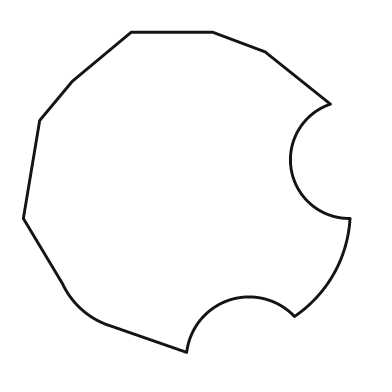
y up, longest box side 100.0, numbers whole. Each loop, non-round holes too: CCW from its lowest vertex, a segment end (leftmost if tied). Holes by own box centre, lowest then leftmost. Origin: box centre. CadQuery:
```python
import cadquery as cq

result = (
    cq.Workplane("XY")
    .moveTo(0.0, -49.0)
    .threePointArc((13.0, -33.0), (33.0, -38.0))
    .threePointArc((45.0, -25.0), (50.0, -8.0))
    .threePointArc((32.0, 7.0), (44.0, 27.0))
    .lineTo(24.0, 43.0)
    .lineTo(8.0, 49.0)
    .lineTo(-17.0, 49.0)
    .lineTo(-35.0, 34.0)
    .lineTo(-45.0, 22.0)
    .lineTo(-50.0, -8.0)
    .lineTo(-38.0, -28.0)
    .threePointArc((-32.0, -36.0), (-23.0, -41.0))
    .close()
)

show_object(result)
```